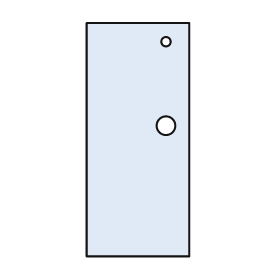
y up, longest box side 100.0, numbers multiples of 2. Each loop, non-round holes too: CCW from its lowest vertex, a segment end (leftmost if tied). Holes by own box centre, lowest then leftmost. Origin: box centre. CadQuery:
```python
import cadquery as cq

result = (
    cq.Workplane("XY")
    .moveTo(-22.0, -50.0)
    .lineTo(22.0, -50.0)
    .lineTo(22.0, 50.0)
    .lineTo(-22.0, 50.0)
    .close()
    .moveTo(12.0, 6.0)
    .circle(4.0)
    .moveTo(12.0, 42.0)
    .circle(2.0)
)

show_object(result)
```